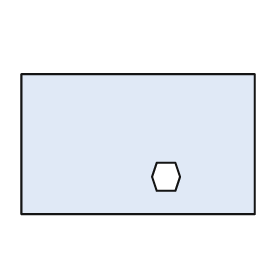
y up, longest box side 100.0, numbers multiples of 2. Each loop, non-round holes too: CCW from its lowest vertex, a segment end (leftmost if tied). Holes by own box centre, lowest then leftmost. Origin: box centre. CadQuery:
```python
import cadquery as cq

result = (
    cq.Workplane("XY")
    .moveTo(-50.0, -30.0)
    .lineTo(50.0, -30.0)
    .lineTo(50.0, 30.0)
    .lineTo(-50.0, 30.0)
    .close()
    .moveTo(8.0, -20.0)
    .lineTo(16.0, -20.0)
    .lineTo(18.0, -14.0)
    .lineTo(16.0, -8.0)
    .lineTo(8.0, -8.0)
    .lineTo(6.0, -14.0)
    .close()
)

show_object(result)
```